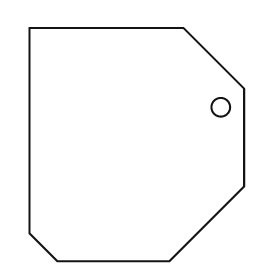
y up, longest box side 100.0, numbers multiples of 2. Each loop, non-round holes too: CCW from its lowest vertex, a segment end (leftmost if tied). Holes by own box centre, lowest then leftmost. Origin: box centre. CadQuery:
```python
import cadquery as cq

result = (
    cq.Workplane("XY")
    .moveTo(-34.0, -50.0)
    .lineTo(14.0, -50.0)
    .lineTo(46.0, -18.0)
    .lineTo(46.0, 24.0)
    .lineTo(20.0, 50.0)
    .lineTo(-46.0, 50.0)
    .lineTo(-46.0, -38.0)
    .close()
    .moveTo(36.0, 16.0)
    .circle(4.0)
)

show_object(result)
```